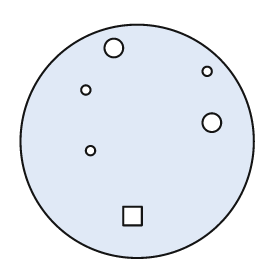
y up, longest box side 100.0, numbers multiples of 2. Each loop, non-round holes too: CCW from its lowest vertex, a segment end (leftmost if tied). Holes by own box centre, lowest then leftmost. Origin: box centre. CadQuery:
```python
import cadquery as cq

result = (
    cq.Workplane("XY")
    .moveTo(0.0, 0.0)
    .circle(50.0)
    .moveTo(-6.0, -36.0)
    .lineTo(2.0, -36.0)
    .lineTo(2.0, -28.0)
    .lineTo(-6.0, -28.0)
    .close()
    .moveTo(-20.0, -4.0)
    .circle(2.0)
    .moveTo(32.0, 8.0)
    .circle(4.0)
    .moveTo(-22.0, 22.0)
    .circle(2.0)
    .moveTo(30.0, 30.0)
    .circle(2.0)
    .moveTo(-10.0, 40.0)
    .circle(4.0)
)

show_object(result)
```